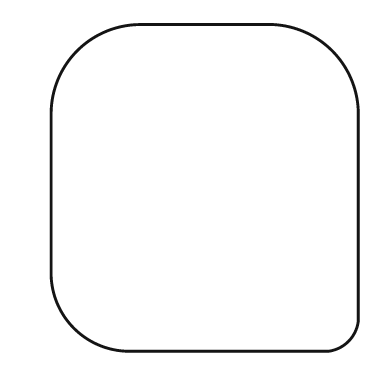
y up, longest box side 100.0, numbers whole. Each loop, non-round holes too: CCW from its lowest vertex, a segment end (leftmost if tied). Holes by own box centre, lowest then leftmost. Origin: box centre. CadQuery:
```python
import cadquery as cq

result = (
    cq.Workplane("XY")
    .moveTo(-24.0, -50.0)
    .lineTo(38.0, -50.0)
    .threePointArc((44.0, -47.0), (47.0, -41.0))
    .lineTo(47.0, 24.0)
    .threePointArc((39.0, 42.0), (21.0, 50.0))
    .lineTo(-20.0, 50.0)
    .threePointArc((-39.0, 42.0), (-47.0, 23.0))
    .lineTo(-47.0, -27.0)
    .threePointArc((-40.0, -43.0), (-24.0, -50.0))
    .close()
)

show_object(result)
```